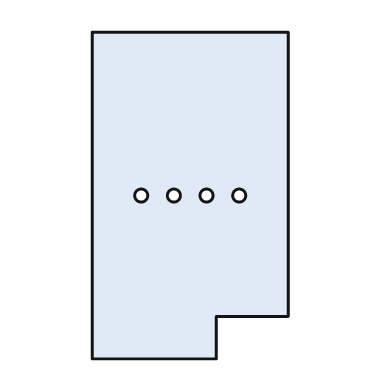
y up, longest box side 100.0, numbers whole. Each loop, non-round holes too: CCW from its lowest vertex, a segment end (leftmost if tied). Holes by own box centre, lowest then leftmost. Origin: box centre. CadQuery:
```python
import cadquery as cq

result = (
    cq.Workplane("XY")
    .moveTo(-30.0, -50.0)
    .lineTo(8.0, -50.0)
    .lineTo(8.0, -37.0)
    .lineTo(30.0, -37.0)
    .lineTo(30.0, 50.0)
    .lineTo(-30.0, 50.0)
    .close()
    .moveTo(-15.0, 0.0)
    .circle(2.0)
    .moveTo(-5.0, 0.0)
    .circle(2.0)
    .moveTo(5.0, 0.0)
    .circle(2.0)
    .moveTo(15.0, 0.0)
    .circle(2.0)
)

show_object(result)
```